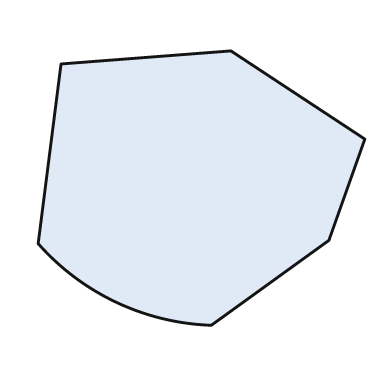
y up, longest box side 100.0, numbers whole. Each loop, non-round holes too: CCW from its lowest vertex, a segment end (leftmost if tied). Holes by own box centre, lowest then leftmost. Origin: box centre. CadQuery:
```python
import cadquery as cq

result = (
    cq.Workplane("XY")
    .moveTo(3.0, -42.0)
    .lineTo(39.0, -16.0)
    .lineTo(50.0, 15.0)
    .lineTo(9.0, 42.0)
    .lineTo(-43.0, 38.0)
    .lineTo(-50.0, -17.0)
    .threePointArc((-26.0, -35.0), (3.0, -42.0))
    .close()
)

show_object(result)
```